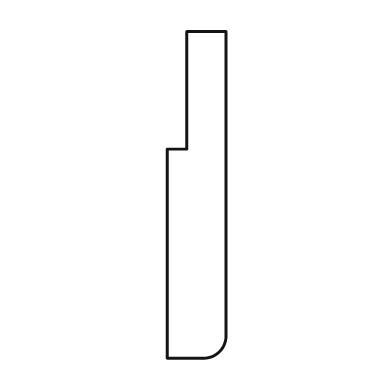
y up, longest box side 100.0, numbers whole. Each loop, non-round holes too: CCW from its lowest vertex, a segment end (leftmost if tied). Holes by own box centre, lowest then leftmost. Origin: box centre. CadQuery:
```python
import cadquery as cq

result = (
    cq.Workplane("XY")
    .moveTo(-9.0, -50.0)
    .lineTo(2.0, -50.0)
    .threePointArc((7.0, -48.0), (9.0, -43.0))
    .lineTo(9.0, 50.0)
    .lineTo(-3.0, 50.0)
    .lineTo(-3.0, 14.0)
    .lineTo(-9.0, 14.0)
    .close()
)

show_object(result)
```